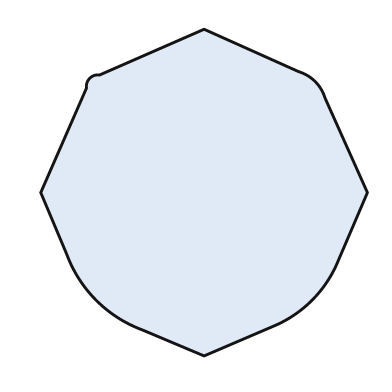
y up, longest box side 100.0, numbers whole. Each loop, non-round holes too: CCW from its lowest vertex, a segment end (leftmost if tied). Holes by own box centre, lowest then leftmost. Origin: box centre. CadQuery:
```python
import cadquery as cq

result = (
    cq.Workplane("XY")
    .moveTo(0.0, -50.0)
    .lineTo(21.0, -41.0)
    .threePointArc((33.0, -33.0), (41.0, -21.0))
    .lineTo(50.0, 0.0)
    .lineTo(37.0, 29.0)
    .threePointArc((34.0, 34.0), (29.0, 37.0))
    .lineTo(0.0, 50.0)
    .lineTo(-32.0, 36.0)
    .threePointArc((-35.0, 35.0), (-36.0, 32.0))
    .lineTo(-50.0, 0.0)
    .lineTo(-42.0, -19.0)
    .threePointArc((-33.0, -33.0), (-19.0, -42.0))
    .close()
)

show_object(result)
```